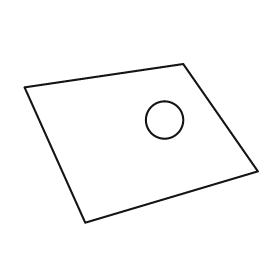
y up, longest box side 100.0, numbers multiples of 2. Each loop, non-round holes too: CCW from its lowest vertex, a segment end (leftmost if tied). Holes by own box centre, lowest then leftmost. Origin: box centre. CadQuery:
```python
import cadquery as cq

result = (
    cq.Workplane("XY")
    .moveTo(-24.0, -34.0)
    .lineTo(50.0, -12.0)
    .lineTo(18.0, 34.0)
    .lineTo(-50.0, 24.0)
    .close()
    .moveTo(10.0, 10.0)
    .circle(8.0)
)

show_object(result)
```